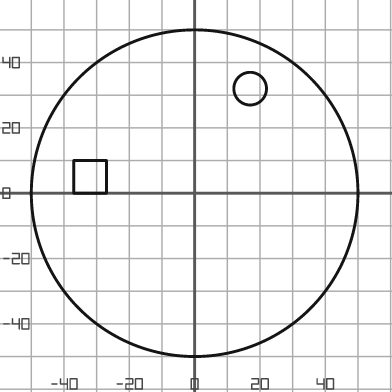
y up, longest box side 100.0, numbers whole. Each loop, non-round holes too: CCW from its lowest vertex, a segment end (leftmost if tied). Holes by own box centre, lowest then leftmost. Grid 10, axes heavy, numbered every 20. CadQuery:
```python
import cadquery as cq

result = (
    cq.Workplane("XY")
    .moveTo(0.0, 0.0)
    .circle(50.0)
    .moveTo(-37.0, 0.0)
    .lineTo(-27.0, 0.0)
    .lineTo(-27.0, 10.0)
    .lineTo(-37.0, 10.0)
    .close()
    .moveTo(17.0, 32.0)
    .circle(5.0)
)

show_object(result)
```